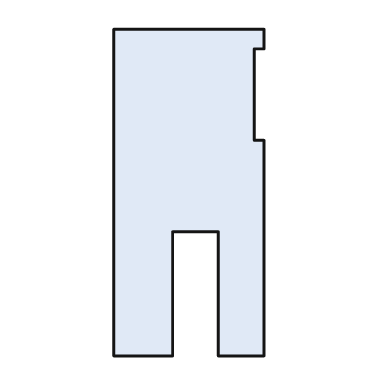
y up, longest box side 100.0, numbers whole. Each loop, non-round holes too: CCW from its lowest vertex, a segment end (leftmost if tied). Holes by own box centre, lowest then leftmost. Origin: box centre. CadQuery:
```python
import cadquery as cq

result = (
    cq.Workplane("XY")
    .moveTo(-23.0, -50.0)
    .lineTo(-5.0, -50.0)
    .lineTo(-5.0, -12.0)
    .lineTo(9.0, -12.0)
    .lineTo(9.0, -50.0)
    .lineTo(23.0, -50.0)
    .lineTo(23.0, 16.0)
    .lineTo(20.0, 16.0)
    .lineTo(20.0, 44.0)
    .lineTo(23.0, 44.0)
    .lineTo(23.0, 50.0)
    .lineTo(-23.0, 50.0)
    .close()
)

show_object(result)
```